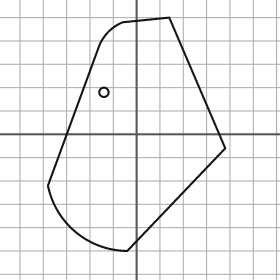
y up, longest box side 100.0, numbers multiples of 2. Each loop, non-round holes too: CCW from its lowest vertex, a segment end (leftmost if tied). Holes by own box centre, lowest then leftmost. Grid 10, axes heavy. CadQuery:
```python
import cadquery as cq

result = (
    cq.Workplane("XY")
    .moveTo(-4.0, -50.0)
    .lineTo(38.0, -6.0)
    .lineTo(14.0, 50.0)
    .lineTo(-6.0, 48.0)
    .threePointArc((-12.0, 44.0), (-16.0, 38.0))
    .lineTo(-38.0, -22.0)
    .threePointArc((-26.0, -42.0), (-4.0, -50.0))
    .close()
    .moveTo(-14.0, 18.0)
    .circle(2.0)
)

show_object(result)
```